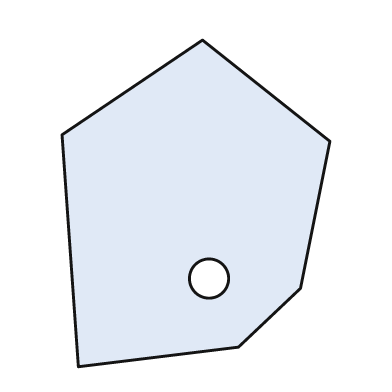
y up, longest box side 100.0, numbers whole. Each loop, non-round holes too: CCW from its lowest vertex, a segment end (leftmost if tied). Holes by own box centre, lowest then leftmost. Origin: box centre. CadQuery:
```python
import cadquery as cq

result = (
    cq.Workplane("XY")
    .moveTo(-36.0, -50.0)
    .lineTo(13.0, -44.0)
    .lineTo(32.0, -26.0)
    .lineTo(41.0, 19.0)
    .lineTo(2.0, 50.0)
    .lineTo(-41.0, 21.0)
    .close()
    .moveTo(4.0, -23.0)
    .circle(6.0)
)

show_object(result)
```